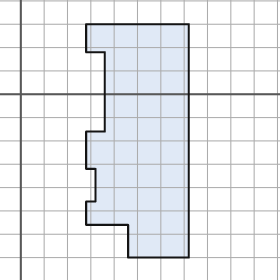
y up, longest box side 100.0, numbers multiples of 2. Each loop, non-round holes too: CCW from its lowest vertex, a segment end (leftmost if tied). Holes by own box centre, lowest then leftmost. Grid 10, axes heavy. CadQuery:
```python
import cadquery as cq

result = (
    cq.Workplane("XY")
    .moveTo(46.0, -70.0)
    .lineTo(72.0, -70.0)
    .lineTo(72.0, 30.0)
    .lineTo(28.0, 30.0)
    .lineTo(28.0, 18.0)
    .lineTo(36.0, 18.0)
    .lineTo(36.0, -16.0)
    .lineTo(28.0, -16.0)
    .lineTo(28.0, -32.0)
    .lineTo(32.0, -32.0)
    .lineTo(32.0, -46.0)
    .lineTo(28.0, -46.0)
    .lineTo(28.0, -56.0)
    .lineTo(46.0, -56.0)
    .close()
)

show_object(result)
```